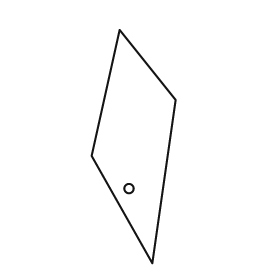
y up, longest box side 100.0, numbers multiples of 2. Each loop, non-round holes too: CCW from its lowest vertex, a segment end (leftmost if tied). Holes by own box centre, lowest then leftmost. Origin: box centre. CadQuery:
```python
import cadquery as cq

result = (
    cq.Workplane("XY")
    .moveTo(8.0, -50.0)
    .lineTo(18.0, 20.0)
    .lineTo(-6.0, 50.0)
    .lineTo(-18.0, -4.0)
    .close()
    .moveTo(-2.0, -18.0)
    .circle(2.0)
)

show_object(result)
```